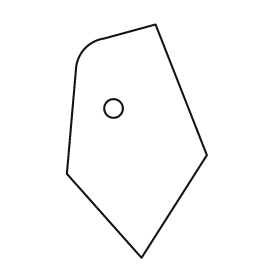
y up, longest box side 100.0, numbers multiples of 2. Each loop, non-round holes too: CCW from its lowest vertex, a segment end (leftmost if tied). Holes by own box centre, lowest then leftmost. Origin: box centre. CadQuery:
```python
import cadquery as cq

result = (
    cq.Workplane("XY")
    .moveTo(2.0, -50.0)
    .lineTo(30.0, -6.0)
    .lineTo(8.0, 50.0)
    .lineTo(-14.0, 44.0)
    .threePointArc((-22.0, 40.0), (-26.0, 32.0))
    .lineTo(-30.0, -14.0)
    .close()
    .moveTo(-10.0, 14.0)
    .circle(4.0)
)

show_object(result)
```